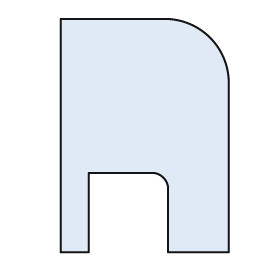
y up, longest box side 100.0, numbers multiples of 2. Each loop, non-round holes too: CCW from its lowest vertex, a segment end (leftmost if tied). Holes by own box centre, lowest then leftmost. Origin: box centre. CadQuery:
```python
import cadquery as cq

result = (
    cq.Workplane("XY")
    .moveTo(-36.0, -50.0)
    .lineTo(-24.0, -50.0)
    .lineTo(-24.0, -16.0)
    .lineTo(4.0, -16.0)
    .threePointArc((8.0, -18.0), (10.0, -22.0))
    .lineTo(10.0, -50.0)
    .lineTo(36.0, -50.0)
    .lineTo(36.0, 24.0)
    .threePointArc((28.0, 42.0), (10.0, 50.0))
    .lineTo(-36.0, 50.0)
    .close()
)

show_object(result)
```